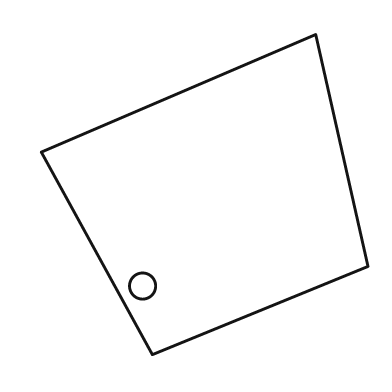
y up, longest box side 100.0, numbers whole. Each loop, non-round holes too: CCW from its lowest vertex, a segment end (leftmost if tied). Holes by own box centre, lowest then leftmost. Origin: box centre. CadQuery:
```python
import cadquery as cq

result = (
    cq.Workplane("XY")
    .moveTo(-16.0, -49.0)
    .lineTo(50.0, -22.0)
    .lineTo(34.0, 49.0)
    .lineTo(-50.0, 13.0)
    .close()
    .moveTo(-19.0, -28.0)
    .circle(4.0)
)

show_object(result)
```